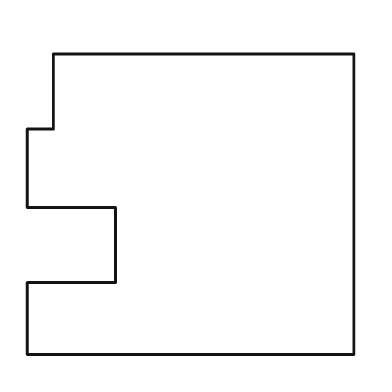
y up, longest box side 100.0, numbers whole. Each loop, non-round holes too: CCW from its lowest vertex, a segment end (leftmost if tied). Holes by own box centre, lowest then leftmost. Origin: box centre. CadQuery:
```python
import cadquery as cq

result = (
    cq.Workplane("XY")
    .moveTo(-50.0, -46.0)
    .lineTo(50.0, -46.0)
    .lineTo(50.0, 46.0)
    .lineTo(-42.0, 46.0)
    .lineTo(-42.0, 23.0)
    .lineTo(-50.0, 23.0)
    .lineTo(-50.0, -1.0)
    .lineTo(-23.0, -1.0)
    .lineTo(-23.0, -24.0)
    .lineTo(-50.0, -24.0)
    .close()
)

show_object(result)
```